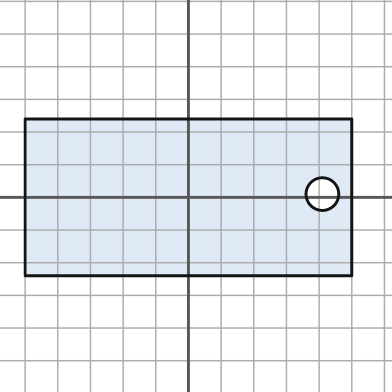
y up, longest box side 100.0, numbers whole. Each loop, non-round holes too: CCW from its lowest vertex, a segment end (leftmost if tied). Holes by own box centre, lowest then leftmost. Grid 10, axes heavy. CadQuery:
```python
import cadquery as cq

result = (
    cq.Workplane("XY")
    .moveTo(-50.0, -24.0)
    .lineTo(50.0, -24.0)
    .lineTo(50.0, 24.0)
    .lineTo(-50.0, 24.0)
    .close()
    .moveTo(41.0, 1.0)
    .circle(5.0)
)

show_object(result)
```